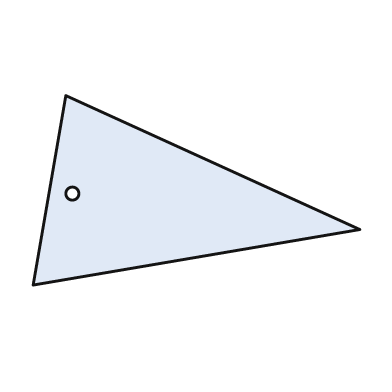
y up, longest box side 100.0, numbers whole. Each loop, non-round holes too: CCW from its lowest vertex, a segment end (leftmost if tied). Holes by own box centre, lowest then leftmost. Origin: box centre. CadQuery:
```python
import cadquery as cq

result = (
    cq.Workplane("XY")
    .moveTo(-50.0, -29.0)
    .lineTo(50.0, -12.0)
    .lineTo(-40.0, 29.0)
    .close()
    .moveTo(-38.0, -1.0)
    .circle(2.0)
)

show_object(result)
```